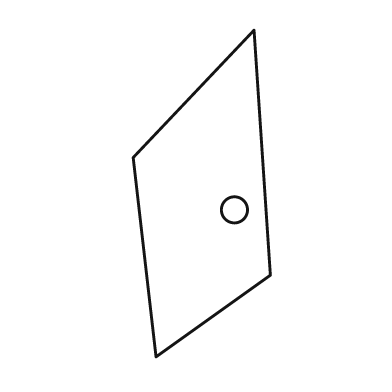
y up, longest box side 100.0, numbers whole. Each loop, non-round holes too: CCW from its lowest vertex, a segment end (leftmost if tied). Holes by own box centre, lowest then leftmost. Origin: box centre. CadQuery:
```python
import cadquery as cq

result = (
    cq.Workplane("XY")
    .moveTo(-14.0, -50.0)
    .lineTo(21.0, -25.0)
    .lineTo(16.0, 50.0)
    .lineTo(-21.0, 11.0)
    .close()
    .moveTo(10.0, -5.0)
    .circle(4.0)
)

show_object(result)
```